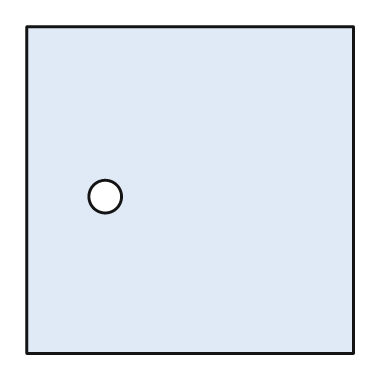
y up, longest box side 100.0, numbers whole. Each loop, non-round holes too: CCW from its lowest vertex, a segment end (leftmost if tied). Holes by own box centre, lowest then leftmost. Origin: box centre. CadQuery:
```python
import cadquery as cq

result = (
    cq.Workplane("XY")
    .moveTo(-50.0, -50.0)
    .lineTo(50.0, -50.0)
    .lineTo(50.0, 50.0)
    .lineTo(-50.0, 50.0)
    .close()
    .moveTo(-26.0, -2.0)
    .circle(5.0)
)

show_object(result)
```